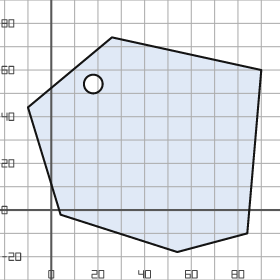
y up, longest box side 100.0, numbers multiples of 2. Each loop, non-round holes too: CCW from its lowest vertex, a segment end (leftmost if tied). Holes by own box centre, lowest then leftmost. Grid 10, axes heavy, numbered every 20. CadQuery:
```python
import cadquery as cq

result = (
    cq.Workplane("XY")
    .moveTo(54.0, -18.0)
    .lineTo(84.0, -10.0)
    .lineTo(90.0, 60.0)
    .lineTo(26.0, 74.0)
    .lineTo(-10.0, 44.0)
    .lineTo(4.0, -2.0)
    .close()
    .moveTo(18.0, 54.0)
    .circle(4.0)
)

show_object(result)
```